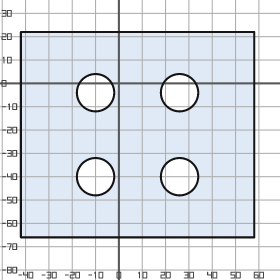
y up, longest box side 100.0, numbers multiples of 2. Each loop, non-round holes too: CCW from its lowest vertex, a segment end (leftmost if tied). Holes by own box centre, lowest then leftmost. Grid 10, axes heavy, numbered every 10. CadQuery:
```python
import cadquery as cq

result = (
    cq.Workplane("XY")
    .moveTo(-42.0, -66.0)
    .lineTo(58.0, -66.0)
    .lineTo(58.0, 22.0)
    .lineTo(-42.0, 22.0)
    .close()
    .moveTo(-10.0, -40.0)
    .circle(8.0)
    .moveTo(26.0, -40.0)
    .circle(8.0)
    .moveTo(-10.0, -4.0)
    .circle(8.0)
    .moveTo(26.0, -4.0)
    .circle(8.0)
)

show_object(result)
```